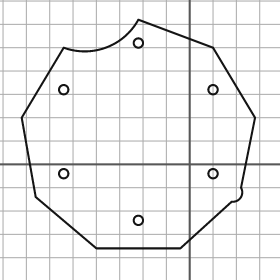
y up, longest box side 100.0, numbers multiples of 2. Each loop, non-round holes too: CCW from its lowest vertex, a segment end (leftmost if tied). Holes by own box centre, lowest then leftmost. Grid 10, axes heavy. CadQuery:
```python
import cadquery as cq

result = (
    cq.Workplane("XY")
    .moveTo(-40.0, -36.0)
    .lineTo(-4.0, -36.0)
    .lineTo(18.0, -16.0)
    .threePointArc((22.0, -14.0), (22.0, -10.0))
    .lineTo(28.0, 20.0)
    .lineTo(10.0, 50.0)
    .lineTo(-22.0, 62.0)
    .threePointArc((-36.0, 50.0), (-54.0, 50.0))
    .lineTo(-72.0, 20.0)
    .lineTo(-66.0, -14.0)
    .close()
    .moveTo(-22.0, -24.0)
    .circle(2.0)
    .moveTo(-54.0, -4.0)
    .circle(2.0)
    .moveTo(10.0, -4.0)
    .circle(2.0)
    .moveTo(-54.0, 32.0)
    .circle(2.0)
    .moveTo(10.0, 32.0)
    .circle(2.0)
    .moveTo(-22.0, 52.0)
    .circle(2.0)
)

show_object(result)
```